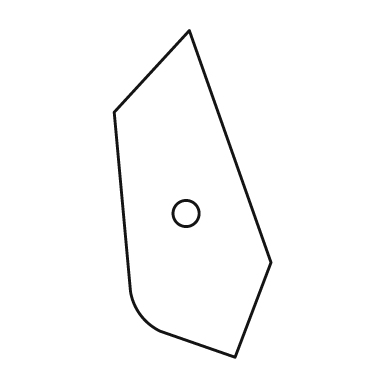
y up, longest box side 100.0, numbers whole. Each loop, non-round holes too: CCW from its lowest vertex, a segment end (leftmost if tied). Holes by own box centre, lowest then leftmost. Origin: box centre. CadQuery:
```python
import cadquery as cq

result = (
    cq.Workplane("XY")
    .moveTo(13.0, -50.0)
    .lineTo(24.0, -21.0)
    .lineTo(-1.0, 50.0)
    .lineTo(-24.0, 25.0)
    .lineTo(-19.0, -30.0)
    .threePointArc((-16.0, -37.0), (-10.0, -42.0))
    .close()
    .moveTo(-2.0, -6.0)
    .circle(4.0)
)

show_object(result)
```